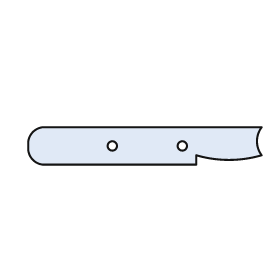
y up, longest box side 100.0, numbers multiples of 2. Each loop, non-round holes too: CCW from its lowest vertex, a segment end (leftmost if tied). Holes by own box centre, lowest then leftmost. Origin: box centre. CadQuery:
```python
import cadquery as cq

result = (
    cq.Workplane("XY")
    .moveTo(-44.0, -8.0)
    .lineTo(22.0, -8.0)
    .lineTo(22.0, -4.0)
    .threePointArc((36.0, -6.0), (50.0, -4.0))
    .threePointArc((48.0, 2.0), (50.0, 8.0))
    .lineTo(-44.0, 8.0)
    .threePointArc((-48.0, 6.0), (-50.0, 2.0))
    .lineTo(-50.0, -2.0)
    .threePointArc((-48.0, -6.0), (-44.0, -8.0))
    .close()
    .moveTo(-14.0, 0.0)
    .circle(2.0)
    .moveTo(16.0, 0.0)
    .circle(2.0)
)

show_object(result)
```